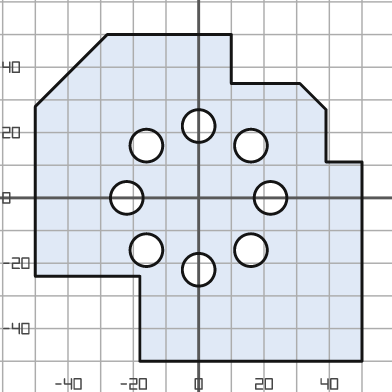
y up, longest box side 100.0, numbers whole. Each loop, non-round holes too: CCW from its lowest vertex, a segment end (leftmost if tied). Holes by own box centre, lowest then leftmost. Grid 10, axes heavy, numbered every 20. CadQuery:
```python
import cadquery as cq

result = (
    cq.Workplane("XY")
    .moveTo(-18.0, -50.0)
    .lineTo(50.0, -50.0)
    .lineTo(50.0, 11.0)
    .lineTo(39.0, 11.0)
    .lineTo(39.0, 27.0)
    .lineTo(31.0, 35.0)
    .lineTo(10.0, 35.0)
    .lineTo(10.0, 50.0)
    .lineTo(-28.0, 50.0)
    .lineTo(-50.0, 28.0)
    .lineTo(-50.0, -24.0)
    .lineTo(-18.0, -24.0)
    .close()
    .moveTo(0.0, -22.0)
    .circle(5.0)
    .moveTo(-16.0, -16.0)
    .circle(5.0)
    .moveTo(16.0, -16.0)
    .circle(5.0)
    .moveTo(-22.0, 0.0)
    .circle(5.0)
    .moveTo(22.0, 0.0)
    .circle(5.0)
    .moveTo(-16.0, 16.0)
    .circle(5.0)
    .moveTo(16.0, 16.0)
    .circle(5.0)
    .moveTo(0.0, 22.0)
    .circle(5.0)
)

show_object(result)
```